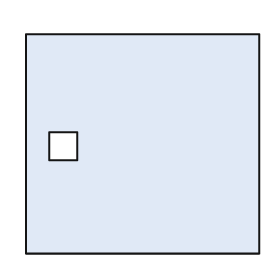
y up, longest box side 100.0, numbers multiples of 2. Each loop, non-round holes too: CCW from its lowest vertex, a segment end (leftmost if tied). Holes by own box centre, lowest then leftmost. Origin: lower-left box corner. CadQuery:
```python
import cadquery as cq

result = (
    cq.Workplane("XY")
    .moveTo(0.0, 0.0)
    .lineTo(100.0, 0.0)
    .lineTo(100.0, 94.0)
    .lineTo(0.0, 94.0)
    .close()
    .moveTo(10.0, 40.0)
    .lineTo(22.0, 40.0)
    .lineTo(22.0, 52.0)
    .lineTo(10.0, 52.0)
    .close()
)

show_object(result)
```